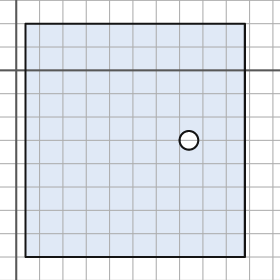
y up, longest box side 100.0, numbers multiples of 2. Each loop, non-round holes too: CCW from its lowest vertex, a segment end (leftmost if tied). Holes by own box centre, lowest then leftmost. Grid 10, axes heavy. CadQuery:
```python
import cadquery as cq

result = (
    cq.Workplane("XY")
    .moveTo(4.0, -80.0)
    .lineTo(98.0, -80.0)
    .lineTo(98.0, 20.0)
    .lineTo(4.0, 20.0)
    .close()
    .moveTo(74.0, -30.0)
    .circle(4.0)
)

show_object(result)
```